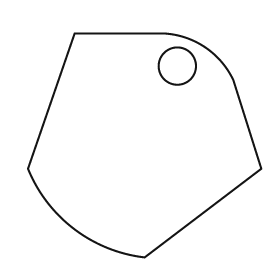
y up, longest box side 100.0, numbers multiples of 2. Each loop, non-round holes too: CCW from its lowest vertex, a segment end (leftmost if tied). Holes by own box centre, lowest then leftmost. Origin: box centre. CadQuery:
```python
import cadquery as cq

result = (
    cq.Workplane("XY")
    .moveTo(0.0, -48.0)
    .lineTo(50.0, -10.0)
    .lineTo(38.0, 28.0)
    .threePointArc((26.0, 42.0), (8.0, 48.0))
    .lineTo(-30.0, 48.0)
    .lineTo(-50.0, -10.0)
    .threePointArc((-30.0, -36.0), (0.0, -48.0))
    .close()
    .moveTo(14.0, 34.0)
    .circle(8.0)
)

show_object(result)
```